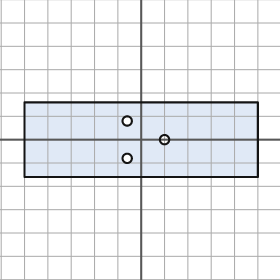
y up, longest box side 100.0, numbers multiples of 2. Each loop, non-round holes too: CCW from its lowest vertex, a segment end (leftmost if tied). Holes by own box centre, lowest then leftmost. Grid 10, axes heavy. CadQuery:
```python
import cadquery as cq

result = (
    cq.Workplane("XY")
    .moveTo(-50.0, -16.0)
    .lineTo(50.0, -16.0)
    .lineTo(50.0, 16.0)
    .lineTo(-50.0, 16.0)
    .close()
    .moveTo(-6.0, -8.0)
    .circle(2.0)
    .moveTo(10.0, 0.0)
    .circle(2.0)
    .moveTo(-6.0, 8.0)
    .circle(2.0)
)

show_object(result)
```